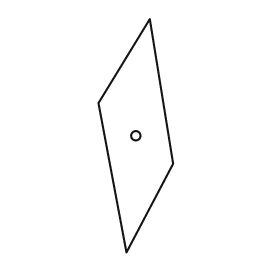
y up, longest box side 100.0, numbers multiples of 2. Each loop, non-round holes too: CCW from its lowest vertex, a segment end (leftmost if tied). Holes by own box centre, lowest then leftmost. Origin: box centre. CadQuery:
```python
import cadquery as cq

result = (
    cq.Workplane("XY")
    .moveTo(-4.0, -50.0)
    .lineTo(16.0, -12.0)
    .lineTo(6.0, 50.0)
    .lineTo(-16.0, 14.0)
    .close()
    .moveTo(0.0, 0.0)
    .circle(2.0)
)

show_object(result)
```